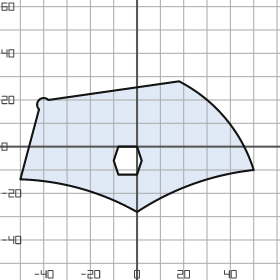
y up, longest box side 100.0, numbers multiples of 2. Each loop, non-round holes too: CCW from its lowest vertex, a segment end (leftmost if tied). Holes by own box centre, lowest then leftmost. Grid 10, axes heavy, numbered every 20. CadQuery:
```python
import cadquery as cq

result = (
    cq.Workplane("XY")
    .moveTo(0.0, -28.0)
    .threePointArc((24.0, -16.0), (50.0, -10.0))
    .threePointArc((38.0, 12.0), (18.0, 28.0))
    .lineTo(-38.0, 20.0)
    .threePointArc((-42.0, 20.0), (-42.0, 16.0))
    .lineTo(-50.0, -14.0)
    .threePointArc((-24.0, -18.0), (0.0, -28.0))
    .close()
    .moveTo(-8.0, -12.0)
    .lineTo(0.0, -12.0)
    .lineTo(2.0, -6.0)
    .lineTo(0.0, 0.0)
    .lineTo(-8.0, 0.0)
    .lineTo(-10.0, -6.0)
    .close()
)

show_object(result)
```